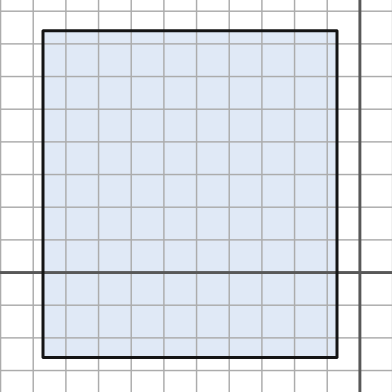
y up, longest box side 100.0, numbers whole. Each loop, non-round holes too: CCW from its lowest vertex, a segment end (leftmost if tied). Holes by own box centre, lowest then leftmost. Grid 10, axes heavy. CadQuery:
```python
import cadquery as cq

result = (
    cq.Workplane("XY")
    .moveTo(-97.0, -26.0)
    .lineTo(-7.0, -26.0)
    .lineTo(-7.0, 74.0)
    .lineTo(-97.0, 74.0)
    .close()
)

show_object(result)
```